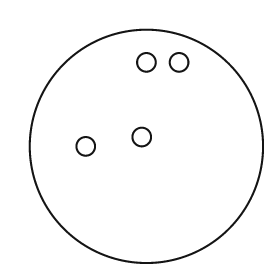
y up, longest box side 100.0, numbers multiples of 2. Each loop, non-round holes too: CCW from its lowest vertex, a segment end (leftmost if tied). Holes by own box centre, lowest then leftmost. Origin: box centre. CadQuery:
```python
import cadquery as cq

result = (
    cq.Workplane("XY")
    .moveTo(0.0, 0.0)
    .circle(50.0)
    .moveTo(-26.0, 0.0)
    .circle(4.0)
    .moveTo(-2.0, 4.0)
    .circle(4.0)
    .moveTo(0.0, 36.0)
    .circle(4.0)
    .moveTo(14.0, 36.0)
    .circle(4.0)
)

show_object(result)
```